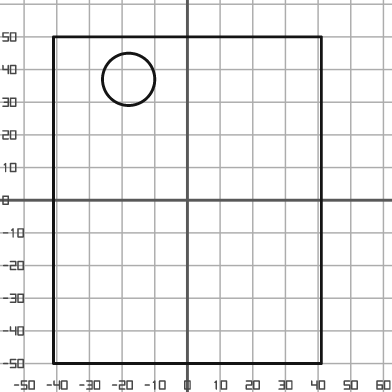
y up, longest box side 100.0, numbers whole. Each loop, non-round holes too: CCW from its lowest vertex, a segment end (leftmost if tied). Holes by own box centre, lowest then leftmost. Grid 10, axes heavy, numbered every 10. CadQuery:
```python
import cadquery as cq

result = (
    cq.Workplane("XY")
    .moveTo(-41.0, -50.0)
    .lineTo(41.0, -50.0)
    .lineTo(41.0, 50.0)
    .lineTo(-41.0, 50.0)
    .close()
    .moveTo(-18.0, 37.0)
    .circle(8.0)
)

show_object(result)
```